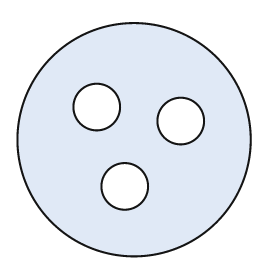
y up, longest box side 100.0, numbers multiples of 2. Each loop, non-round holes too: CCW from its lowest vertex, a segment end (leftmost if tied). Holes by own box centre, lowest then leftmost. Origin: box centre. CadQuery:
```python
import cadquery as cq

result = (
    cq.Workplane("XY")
    .moveTo(0.0, 0.0)
    .circle(50.0)
    .moveTo(-4.0, -20.0)
    .circle(10.0)
    .moveTo(20.0, 8.0)
    .circle(10.0)
    .moveTo(-16.0, 14.0)
    .circle(10.0)
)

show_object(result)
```